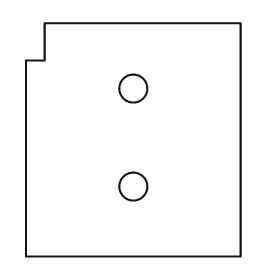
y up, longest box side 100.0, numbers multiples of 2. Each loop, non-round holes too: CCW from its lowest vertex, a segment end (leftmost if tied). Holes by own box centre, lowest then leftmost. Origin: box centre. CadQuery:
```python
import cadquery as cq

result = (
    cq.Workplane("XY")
    .moveTo(-46.0, -50.0)
    .lineTo(46.0, -50.0)
    .lineTo(46.0, 50.0)
    .lineTo(-38.0, 50.0)
    .lineTo(-38.0, 34.0)
    .lineTo(-46.0, 34.0)
    .close()
    .moveTo(0.0, -20.0)
    .circle(6.0)
    .moveTo(0.0, 22.0)
    .circle(6.0)
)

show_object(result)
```